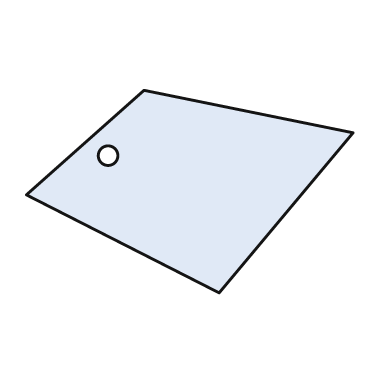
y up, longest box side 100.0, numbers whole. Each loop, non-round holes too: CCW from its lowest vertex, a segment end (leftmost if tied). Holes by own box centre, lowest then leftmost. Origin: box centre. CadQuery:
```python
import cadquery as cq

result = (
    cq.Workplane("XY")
    .moveTo(9.0, -31.0)
    .lineTo(50.0, 18.0)
    .lineTo(-14.0, 31.0)
    .lineTo(-50.0, -1.0)
    .close()
    .moveTo(-25.0, 11.0)
    .circle(3.0)
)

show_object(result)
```